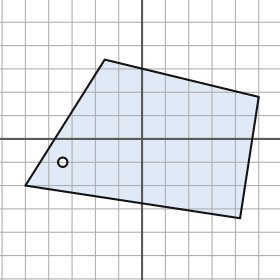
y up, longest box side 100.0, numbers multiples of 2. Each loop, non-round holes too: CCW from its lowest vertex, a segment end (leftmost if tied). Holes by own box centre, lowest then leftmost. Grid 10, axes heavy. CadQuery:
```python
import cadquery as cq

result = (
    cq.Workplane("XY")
    .moveTo(42.0, -34.0)
    .lineTo(50.0, 18.0)
    .lineTo(-16.0, 34.0)
    .lineTo(-50.0, -20.0)
    .close()
    .moveTo(-34.0, -10.0)
    .circle(2.0)
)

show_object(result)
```